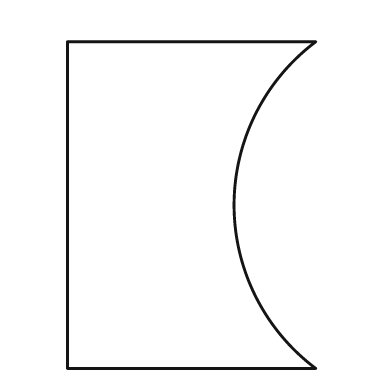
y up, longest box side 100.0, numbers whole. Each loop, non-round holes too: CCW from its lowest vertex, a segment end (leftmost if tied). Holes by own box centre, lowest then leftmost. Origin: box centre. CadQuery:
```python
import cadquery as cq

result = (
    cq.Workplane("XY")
    .moveTo(-38.0, -50.0)
    .lineTo(38.0, -50.0)
    .threePointArc((13.0, 0.0), (38.0, 50.0))
    .lineTo(-38.0, 50.0)
    .close()
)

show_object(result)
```